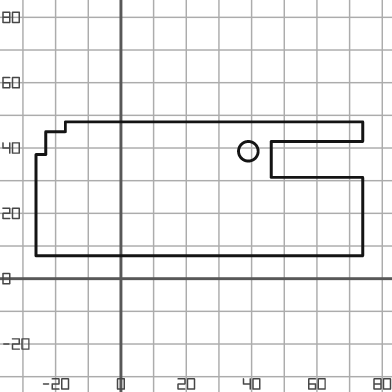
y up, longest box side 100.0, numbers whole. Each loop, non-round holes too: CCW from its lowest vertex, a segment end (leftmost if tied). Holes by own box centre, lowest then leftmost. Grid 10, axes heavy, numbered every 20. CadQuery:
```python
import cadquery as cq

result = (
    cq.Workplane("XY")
    .moveTo(-26.0, 7.0)
    .lineTo(74.0, 7.0)
    .lineTo(74.0, 31.0)
    .lineTo(46.0, 31.0)
    .lineTo(46.0, 42.0)
    .lineTo(74.0, 42.0)
    .lineTo(74.0, 48.0)
    .lineTo(-17.0, 48.0)
    .lineTo(-17.0, 45.0)
    .lineTo(-23.0, 45.0)
    .lineTo(-23.0, 38.0)
    .lineTo(-26.0, 38.0)
    .close()
    .moveTo(39.0, 39.0)
    .circle(3.0)
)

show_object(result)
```